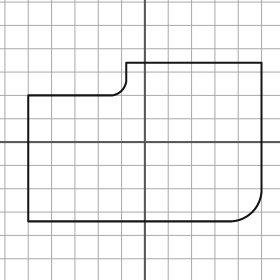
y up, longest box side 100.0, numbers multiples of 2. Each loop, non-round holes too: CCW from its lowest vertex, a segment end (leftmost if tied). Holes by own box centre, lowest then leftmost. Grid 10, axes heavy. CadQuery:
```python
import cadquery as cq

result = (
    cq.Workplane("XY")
    .moveTo(-50.0, -34.0)
    .lineTo(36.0, -34.0)
    .threePointArc((46.0, -30.0), (50.0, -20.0))
    .lineTo(50.0, 34.0)
    .lineTo(-8.0, 34.0)
    .lineTo(-8.0, 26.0)
    .threePointArc((-10.0, 22.0), (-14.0, 20.0))
    .lineTo(-50.0, 20.0)
    .close()
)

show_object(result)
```